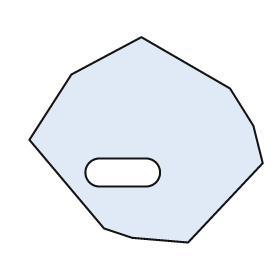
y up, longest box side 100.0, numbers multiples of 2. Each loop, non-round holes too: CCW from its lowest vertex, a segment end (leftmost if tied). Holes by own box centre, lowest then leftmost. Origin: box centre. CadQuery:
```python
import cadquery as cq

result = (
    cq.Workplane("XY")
    .moveTo(18.0, -44.0)
    .lineTo(50.0, -10.0)
    .lineTo(46.0, 6.0)
    .lineTo(36.0, 22.0)
    .lineTo(-2.0, 44.0)
    .lineTo(-32.0, 28.0)
    .lineTo(-50.0, 0.0)
    .lineTo(-18.0, -38.0)
    .lineTo(-6.0, -42.0)
    .close()
    .moveTo(-20.0, -20.0)
    .lineTo(0.0, -20.0)
    .threePointArc((6.0, -14.0), (0.0, -8.0))
    .lineTo(-20.0, -8.0)
    .threePointArc((-26.0, -14.0), (-20.0, -20.0))
    .close()
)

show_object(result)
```